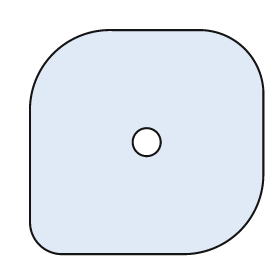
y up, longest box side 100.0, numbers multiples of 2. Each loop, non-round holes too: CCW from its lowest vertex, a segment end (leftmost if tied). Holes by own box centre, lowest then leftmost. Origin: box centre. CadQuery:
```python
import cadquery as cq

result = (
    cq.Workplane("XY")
    .moveTo(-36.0, -48.0)
    .lineTo(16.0, -48.0)
    .threePointArc((40.0, -38.0), (50.0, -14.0))
    .lineTo(50.0, 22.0)
    .threePointArc((42.0, 40.0), (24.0, 48.0))
    .lineTo(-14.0, 48.0)
    .threePointArc((-40.0, 38.0), (-50.0, 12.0))
    .lineTo(-50.0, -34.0)
    .threePointArc((-46.0, -44.0), (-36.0, -48.0))
    .close()
    .moveTo(0.0, 0.0)
    .circle(6.0)
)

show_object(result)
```